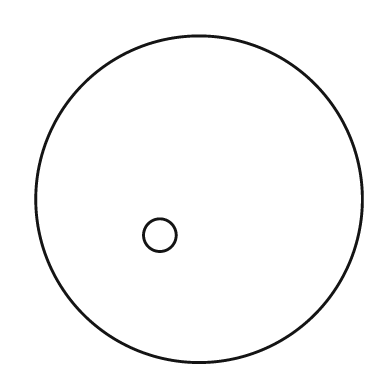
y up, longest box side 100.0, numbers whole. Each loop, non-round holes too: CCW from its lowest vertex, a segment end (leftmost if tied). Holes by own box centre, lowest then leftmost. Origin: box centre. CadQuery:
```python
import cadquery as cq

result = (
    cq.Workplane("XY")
    .moveTo(0.0, 0.0)
    .circle(50.0)
    .moveTo(-12.0, -11.0)
    .circle(5.0)
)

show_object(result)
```